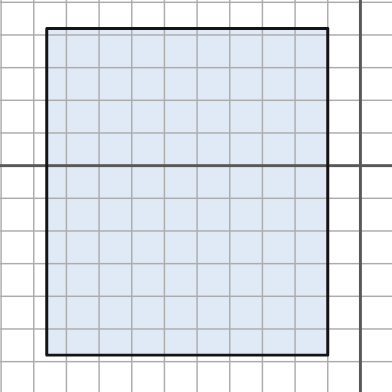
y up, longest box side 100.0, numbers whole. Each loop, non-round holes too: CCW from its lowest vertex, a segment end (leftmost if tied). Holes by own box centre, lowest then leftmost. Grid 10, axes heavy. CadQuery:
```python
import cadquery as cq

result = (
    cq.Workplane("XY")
    .moveTo(-96.0, -58.0)
    .lineTo(-10.0, -58.0)
    .lineTo(-10.0, 42.0)
    .lineTo(-96.0, 42.0)
    .close()
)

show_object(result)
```